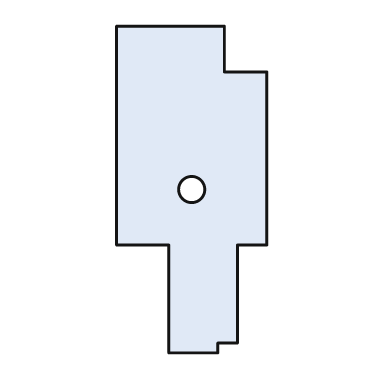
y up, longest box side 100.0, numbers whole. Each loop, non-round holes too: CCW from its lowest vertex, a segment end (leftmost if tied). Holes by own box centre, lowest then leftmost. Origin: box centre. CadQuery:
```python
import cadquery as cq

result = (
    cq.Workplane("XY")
    .moveTo(-7.0, -50.0)
    .lineTo(8.0, -50.0)
    .lineTo(8.0, -47.0)
    .lineTo(14.0, -47.0)
    .lineTo(14.0, -17.0)
    .lineTo(23.0, -17.0)
    .lineTo(23.0, 36.0)
    .lineTo(10.0, 36.0)
    .lineTo(10.0, 50.0)
    .lineTo(-23.0, 50.0)
    .lineTo(-23.0, -17.0)
    .lineTo(-7.0, -17.0)
    .close()
    .moveTo(0.0, 0.0)
    .circle(4.0)
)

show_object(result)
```